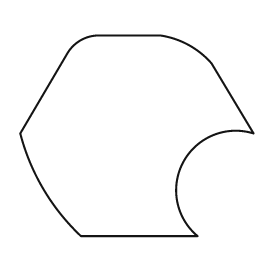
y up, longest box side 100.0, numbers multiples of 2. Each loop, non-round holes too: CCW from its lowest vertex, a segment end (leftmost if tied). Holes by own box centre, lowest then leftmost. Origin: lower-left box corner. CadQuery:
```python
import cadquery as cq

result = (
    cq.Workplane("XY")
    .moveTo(26.0, 0.0)
    .lineTo(76.0, 0.0)
    .threePointArc((70.0, 32.0), (100.0, 44.0))
    .lineTo(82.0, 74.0)
    .threePointArc((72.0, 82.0), (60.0, 86.0))
    .lineTo(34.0, 86.0)
    .threePointArc((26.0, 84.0), (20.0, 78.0))
    .lineTo(0.0, 44.0)
    .threePointArc((10.0, 20.0), (26.0, 0.0))
    .close()
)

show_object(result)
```